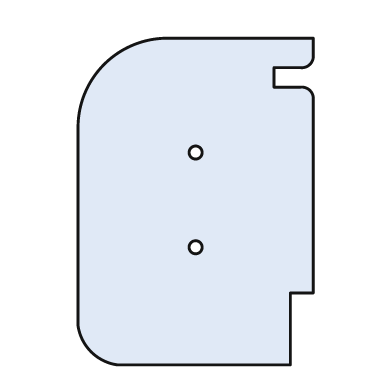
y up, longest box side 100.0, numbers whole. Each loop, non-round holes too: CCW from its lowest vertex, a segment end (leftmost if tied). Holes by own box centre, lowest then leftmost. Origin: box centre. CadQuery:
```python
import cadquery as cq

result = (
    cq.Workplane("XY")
    .moveTo(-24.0, -50.0)
    .lineTo(29.0, -50.0)
    .lineTo(29.0, -28.0)
    .lineTo(36.0, -28.0)
    .lineTo(36.0, 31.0)
    .threePointArc((35.0, 34.0), (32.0, 35.0))
    .lineTo(24.0, 35.0)
    .lineTo(24.0, 41.0)
    .lineTo(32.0, 41.0)
    .threePointArc((35.0, 42.0), (36.0, 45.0))
    .lineTo(36.0, 50.0)
    .lineTo(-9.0, 50.0)
    .threePointArc((-28.0, 42.0), (-36.0, 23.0))
    .lineTo(-36.0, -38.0)
    .threePointArc((-32.0, -46.0), (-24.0, -50.0))
    .close()
    .moveTo(0.0, -14.0)
    .circle(2.0)
    .moveTo(0.0, 15.0)
    .circle(2.0)
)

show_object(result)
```